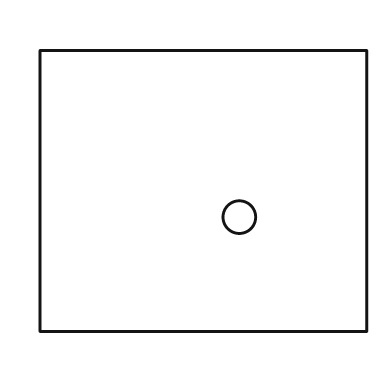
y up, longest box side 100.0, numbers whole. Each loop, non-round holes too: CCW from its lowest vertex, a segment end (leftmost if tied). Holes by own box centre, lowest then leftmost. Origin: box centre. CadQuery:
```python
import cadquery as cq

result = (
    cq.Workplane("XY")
    .moveTo(-50.0, -43.0)
    .lineTo(50.0, -43.0)
    .lineTo(50.0, 43.0)
    .lineTo(-50.0, 43.0)
    .close()
    .moveTo(11.0, -8.0)
    .circle(5.0)
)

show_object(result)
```